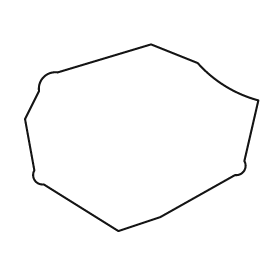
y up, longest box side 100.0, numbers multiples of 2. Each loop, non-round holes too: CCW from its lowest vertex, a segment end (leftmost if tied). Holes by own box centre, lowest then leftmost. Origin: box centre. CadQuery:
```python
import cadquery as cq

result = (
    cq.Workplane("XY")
    .moveTo(-10.0, -40.0)
    .lineTo(8.0, -34.0)
    .lineTo(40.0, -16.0)
    .threePointArc((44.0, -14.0), (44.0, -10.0))
    .lineTo(50.0, 16.0)
    .threePointArc((36.0, 22.0), (24.0, 32.0))
    .lineTo(4.0, 40.0)
    .lineTo(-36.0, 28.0)
    .threePointArc((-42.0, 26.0), (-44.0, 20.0))
    .lineTo(-50.0, 8.0)
    .lineTo(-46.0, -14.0)
    .threePointArc((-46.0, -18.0), (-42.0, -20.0))
    .close()
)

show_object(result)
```